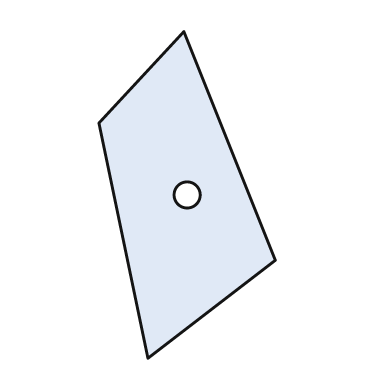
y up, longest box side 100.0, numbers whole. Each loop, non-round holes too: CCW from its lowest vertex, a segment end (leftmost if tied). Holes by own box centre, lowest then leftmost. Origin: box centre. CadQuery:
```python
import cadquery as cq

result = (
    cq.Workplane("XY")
    .moveTo(-12.0, -50.0)
    .lineTo(27.0, -20.0)
    .lineTo(-1.0, 50.0)
    .lineTo(-27.0, 22.0)
    .close()
    .moveTo(0.0, 0.0)
    .circle(4.0)
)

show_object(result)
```